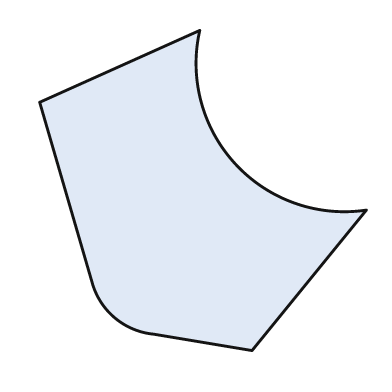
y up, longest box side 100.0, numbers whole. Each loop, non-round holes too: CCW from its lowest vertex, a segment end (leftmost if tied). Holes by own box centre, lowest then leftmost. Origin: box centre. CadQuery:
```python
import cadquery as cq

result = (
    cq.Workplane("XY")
    .moveTo(15.0, -49.0)
    .lineTo(50.0, -6.0)
    .threePointArc((10.0, 8.0), (-1.0, 49.0))
    .lineTo(-50.0, 27.0)
    .lineTo(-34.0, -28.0)
    .threePointArc((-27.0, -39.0), (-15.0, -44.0))
    .close()
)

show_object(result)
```